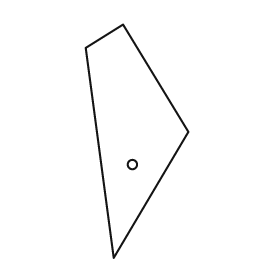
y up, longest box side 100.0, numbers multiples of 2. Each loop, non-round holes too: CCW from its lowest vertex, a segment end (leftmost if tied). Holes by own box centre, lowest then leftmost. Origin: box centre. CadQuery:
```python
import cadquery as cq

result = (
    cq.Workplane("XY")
    .moveTo(-10.0, -50.0)
    .lineTo(22.0, 4.0)
    .lineTo(-6.0, 50.0)
    .lineTo(-22.0, 40.0)
    .close()
    .moveTo(-2.0, -10.0)
    .circle(2.0)
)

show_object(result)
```